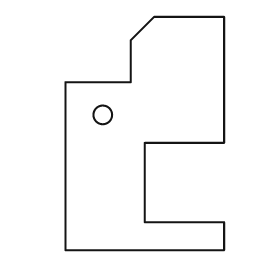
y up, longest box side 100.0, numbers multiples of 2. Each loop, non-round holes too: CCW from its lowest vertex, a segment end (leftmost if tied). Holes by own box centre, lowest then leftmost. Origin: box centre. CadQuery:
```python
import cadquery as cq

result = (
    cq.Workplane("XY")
    .moveTo(-34.0, -50.0)
    .lineTo(34.0, -50.0)
    .lineTo(34.0, -38.0)
    .lineTo(0.0, -38.0)
    .lineTo(0.0, -4.0)
    .lineTo(34.0, -4.0)
    .lineTo(34.0, 50.0)
    .lineTo(4.0, 50.0)
    .lineTo(-6.0, 40.0)
    .lineTo(-6.0, 22.0)
    .lineTo(-34.0, 22.0)
    .close()
    .moveTo(-18.0, 8.0)
    .circle(4.0)
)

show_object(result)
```